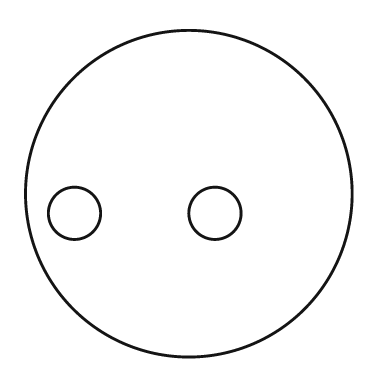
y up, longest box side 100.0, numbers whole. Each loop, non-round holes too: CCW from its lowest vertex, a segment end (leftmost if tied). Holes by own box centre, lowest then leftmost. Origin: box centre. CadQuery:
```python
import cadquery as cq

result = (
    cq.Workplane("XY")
    .moveTo(0.0, 0.0)
    .circle(50.0)
    .moveTo(-35.0, -6.0)
    .circle(8.0)
    .moveTo(8.0, -6.0)
    .circle(8.0)
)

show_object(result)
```